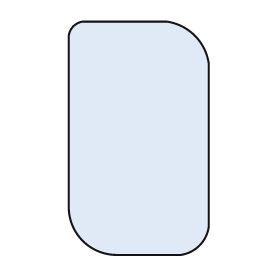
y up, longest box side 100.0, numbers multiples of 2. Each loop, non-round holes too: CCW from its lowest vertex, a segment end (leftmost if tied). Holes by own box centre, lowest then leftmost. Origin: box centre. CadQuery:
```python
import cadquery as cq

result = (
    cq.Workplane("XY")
    .moveTo(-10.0, -50.0)
    .lineTo(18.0, -50.0)
    .threePointArc((26.0, -46.0), (30.0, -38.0))
    .lineTo(30.0, 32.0)
    .threePointArc((24.0, 44.0), (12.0, 50.0))
    .lineTo(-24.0, 50.0)
    .threePointArc((-28.0, 48.0), (-30.0, 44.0))
    .lineTo(-30.0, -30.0)
    .threePointArc((-24.0, -44.0), (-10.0, -50.0))
    .close()
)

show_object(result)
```